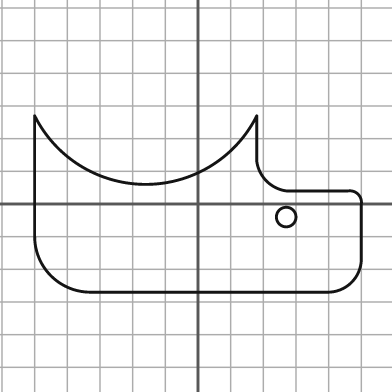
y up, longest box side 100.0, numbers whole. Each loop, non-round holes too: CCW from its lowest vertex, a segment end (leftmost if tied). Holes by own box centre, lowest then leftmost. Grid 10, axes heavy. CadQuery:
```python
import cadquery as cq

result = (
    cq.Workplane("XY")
    .moveTo(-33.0, -27.0)
    .lineTo(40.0, -27.0)
    .threePointArc((47.0, -24.0), (50.0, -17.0))
    .lineTo(50.0, 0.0)
    .threePointArc((49.0, 3.0), (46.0, 4.0))
    .lineTo(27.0, 4.0)
    .threePointArc((21.0, 7.0), (18.0, 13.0))
    .lineTo(18.0, 27.0)
    .threePointArc((-16.0, 6.0), (-50.0, 27.0))
    .lineTo(-50.0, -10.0)
    .threePointArc((-45.0, -22.0), (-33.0, -27.0))
    .close()
    .moveTo(27.0, -4.0)
    .circle(3.0)
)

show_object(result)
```